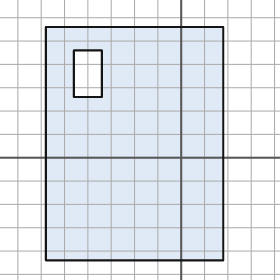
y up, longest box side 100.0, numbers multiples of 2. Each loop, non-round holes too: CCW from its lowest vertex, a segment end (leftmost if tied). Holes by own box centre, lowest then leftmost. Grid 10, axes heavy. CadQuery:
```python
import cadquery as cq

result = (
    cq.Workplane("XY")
    .moveTo(-58.0, -44.0)
    .lineTo(18.0, -44.0)
    .lineTo(18.0, 56.0)
    .lineTo(-58.0, 56.0)
    .close()
    .moveTo(-46.0, 26.0)
    .lineTo(-34.0, 26.0)
    .lineTo(-34.0, 46.0)
    .lineTo(-46.0, 46.0)
    .close()
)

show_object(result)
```